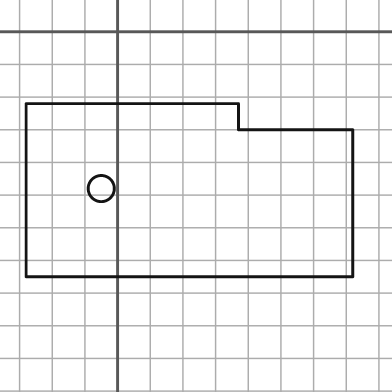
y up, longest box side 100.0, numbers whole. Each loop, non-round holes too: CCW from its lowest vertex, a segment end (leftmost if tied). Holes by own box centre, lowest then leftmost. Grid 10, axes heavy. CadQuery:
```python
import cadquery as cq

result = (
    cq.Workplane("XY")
    .moveTo(-28.0, -75.0)
    .lineTo(72.0, -75.0)
    .lineTo(72.0, -30.0)
    .lineTo(37.0, -30.0)
    .lineTo(37.0, -22.0)
    .lineTo(-28.0, -22.0)
    .close()
    .moveTo(-5.0, -48.0)
    .circle(4.0)
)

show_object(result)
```